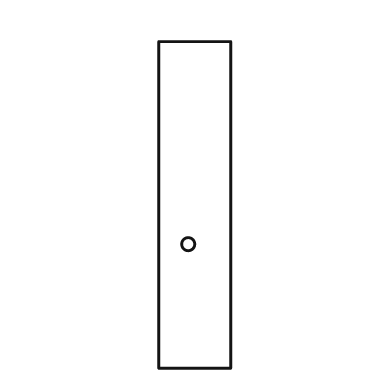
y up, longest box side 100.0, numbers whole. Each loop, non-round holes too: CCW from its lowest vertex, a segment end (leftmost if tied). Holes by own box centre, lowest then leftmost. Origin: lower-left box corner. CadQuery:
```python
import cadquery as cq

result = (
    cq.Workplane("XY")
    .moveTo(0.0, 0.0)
    .lineTo(22.0, 0.0)
    .lineTo(22.0, 100.0)
    .lineTo(0.0, 100.0)
    .close()
    .moveTo(9.0, 38.0)
    .circle(2.0)
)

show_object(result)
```